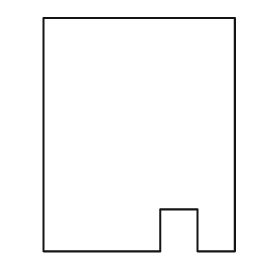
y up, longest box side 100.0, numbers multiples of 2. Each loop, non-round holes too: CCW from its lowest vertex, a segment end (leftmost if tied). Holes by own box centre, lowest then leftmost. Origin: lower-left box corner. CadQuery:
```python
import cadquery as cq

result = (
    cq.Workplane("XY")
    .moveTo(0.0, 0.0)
    .lineTo(50.0, 0.0)
    .lineTo(50.0, 18.0)
    .lineTo(66.0, 18.0)
    .lineTo(66.0, 0.0)
    .lineTo(82.0, 0.0)
    .lineTo(82.0, 100.0)
    .lineTo(0.0, 100.0)
    .close()
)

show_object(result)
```